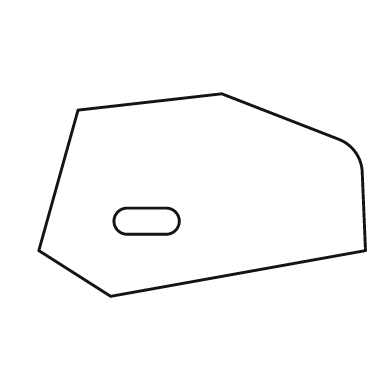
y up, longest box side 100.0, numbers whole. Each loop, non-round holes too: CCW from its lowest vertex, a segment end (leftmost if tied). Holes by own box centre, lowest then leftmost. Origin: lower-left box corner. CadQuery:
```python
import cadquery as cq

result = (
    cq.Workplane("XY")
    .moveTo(22.0, 0.0)
    .lineTo(100.0, 14.0)
    .lineTo(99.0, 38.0)
    .threePointArc((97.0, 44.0), (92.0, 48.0))
    .lineTo(56.0, 62.0)
    .lineTo(12.0, 57.0)
    .lineTo(0.0, 14.0)
    .close()
    .moveTo(27.0, 19.0)
    .lineTo(39.0, 19.0)
    .threePointArc((43.0, 23.0), (39.0, 27.0))
    .lineTo(27.0, 27.0)
    .threePointArc((23.0, 23.0), (27.0, 19.0))
    .close()
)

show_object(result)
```